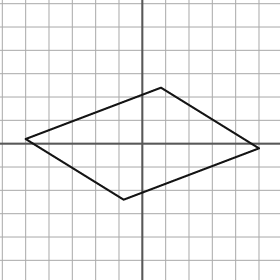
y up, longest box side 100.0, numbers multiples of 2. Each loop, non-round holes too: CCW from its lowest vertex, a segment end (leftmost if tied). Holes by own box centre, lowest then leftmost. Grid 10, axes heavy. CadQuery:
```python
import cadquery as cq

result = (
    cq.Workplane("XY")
    .moveTo(-8.0, -24.0)
    .lineTo(50.0, -2.0)
    .lineTo(8.0, 24.0)
    .lineTo(-50.0, 2.0)
    .close()
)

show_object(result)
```